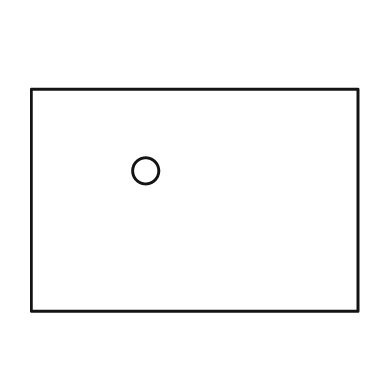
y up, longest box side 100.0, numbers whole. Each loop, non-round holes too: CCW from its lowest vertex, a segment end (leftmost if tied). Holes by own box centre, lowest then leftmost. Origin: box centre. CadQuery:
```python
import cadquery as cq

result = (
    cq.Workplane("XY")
    .moveTo(-50.0, -34.0)
    .lineTo(50.0, -34.0)
    .lineTo(50.0, 34.0)
    .lineTo(-50.0, 34.0)
    .close()
    .moveTo(-15.0, 9.0)
    .circle(4.0)
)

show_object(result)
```